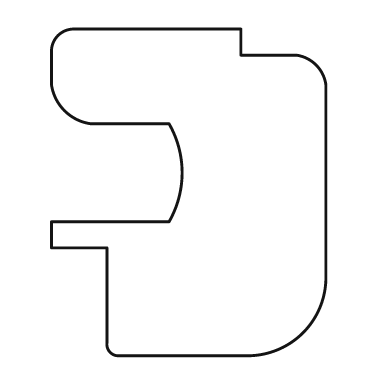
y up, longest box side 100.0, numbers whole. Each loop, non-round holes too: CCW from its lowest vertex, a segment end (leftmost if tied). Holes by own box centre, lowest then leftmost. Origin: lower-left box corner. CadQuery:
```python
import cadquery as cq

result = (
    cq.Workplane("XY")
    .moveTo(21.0, 0.0)
    .lineTo(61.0, 0.0)
    .threePointArc((77.0, 7.0), (84.0, 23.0))
    .lineTo(84.0, 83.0)
    .threePointArc((81.0, 89.0), (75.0, 92.0))
    .lineTo(58.0, 92.0)
    .lineTo(58.0, 100.0)
    .lineTo(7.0, 100.0)
    .threePointArc((2.0, 98.0), (0.0, 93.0))
    .lineTo(0.0, 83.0)
    .threePointArc((4.0, 75.0), (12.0, 71.0))
    .lineTo(36.0, 71.0)
    .threePointArc((40.0, 56.0), (36.0, 41.0))
    .lineTo(0.0, 41.0)
    .lineTo(0.0, 33.0)
    .lineTo(17.0, 33.0)
    .lineTo(17.0, 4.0)
    .threePointArc((18.0, 1.0), (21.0, 0.0))
    .close()
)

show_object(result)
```